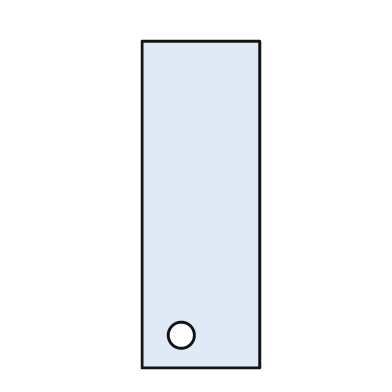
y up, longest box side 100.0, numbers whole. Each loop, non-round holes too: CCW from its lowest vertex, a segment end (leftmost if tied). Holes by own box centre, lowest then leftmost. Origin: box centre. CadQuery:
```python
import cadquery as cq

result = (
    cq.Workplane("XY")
    .moveTo(-18.0, -50.0)
    .lineTo(18.0, -50.0)
    .lineTo(18.0, 50.0)
    .lineTo(-18.0, 50.0)
    .close()
    .moveTo(-6.0, -40.0)
    .circle(4.0)
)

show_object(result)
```